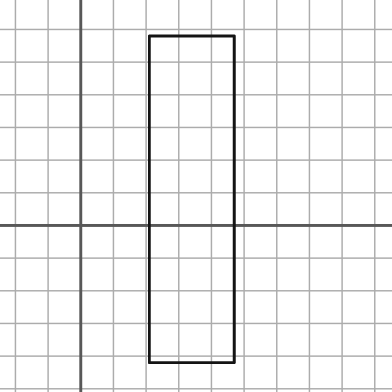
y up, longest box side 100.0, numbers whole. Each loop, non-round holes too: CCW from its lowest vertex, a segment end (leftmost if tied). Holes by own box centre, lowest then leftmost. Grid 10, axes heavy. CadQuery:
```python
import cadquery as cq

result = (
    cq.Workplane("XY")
    .moveTo(21.0, -42.0)
    .lineTo(47.0, -42.0)
    .lineTo(47.0, 58.0)
    .lineTo(21.0, 58.0)
    .close()
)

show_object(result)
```